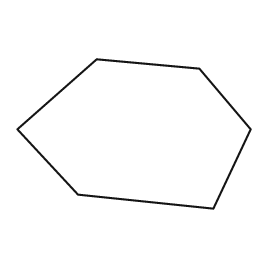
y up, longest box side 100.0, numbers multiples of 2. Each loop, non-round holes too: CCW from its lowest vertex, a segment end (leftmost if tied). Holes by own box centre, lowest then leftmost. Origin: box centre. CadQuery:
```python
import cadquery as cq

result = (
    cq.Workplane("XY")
    .moveTo(34.0, -32.0)
    .lineTo(50.0, 2.0)
    .lineTo(28.0, 28.0)
    .lineTo(-16.0, 32.0)
    .lineTo(-50.0, 2.0)
    .lineTo(-24.0, -26.0)
    .close()
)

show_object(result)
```